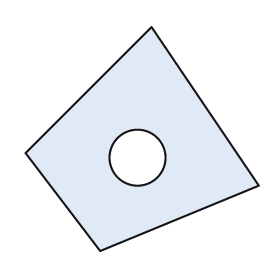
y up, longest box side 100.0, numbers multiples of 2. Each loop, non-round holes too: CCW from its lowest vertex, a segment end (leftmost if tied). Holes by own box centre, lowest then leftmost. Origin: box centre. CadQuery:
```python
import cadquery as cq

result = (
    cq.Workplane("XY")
    .moveTo(-18.0, -48.0)
    .lineTo(50.0, -20.0)
    .lineTo(4.0, 48.0)
    .lineTo(-50.0, -6.0)
    .close()
    .moveTo(-2.0, -8.0)
    .circle(12.0)
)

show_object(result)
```